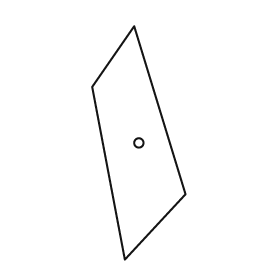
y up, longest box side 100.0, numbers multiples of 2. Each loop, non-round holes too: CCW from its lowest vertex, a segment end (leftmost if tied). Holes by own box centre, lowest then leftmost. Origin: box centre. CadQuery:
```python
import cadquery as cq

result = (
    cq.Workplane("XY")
    .moveTo(-6.0, -50.0)
    .lineTo(20.0, -22.0)
    .lineTo(-2.0, 50.0)
    .lineTo(-20.0, 24.0)
    .close()
    .moveTo(0.0, 0.0)
    .circle(2.0)
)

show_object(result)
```